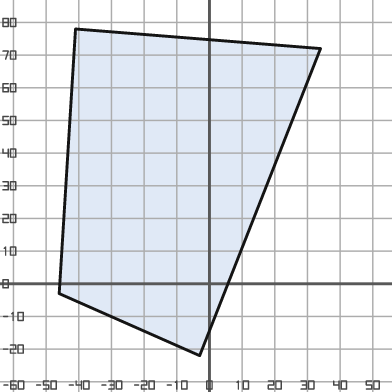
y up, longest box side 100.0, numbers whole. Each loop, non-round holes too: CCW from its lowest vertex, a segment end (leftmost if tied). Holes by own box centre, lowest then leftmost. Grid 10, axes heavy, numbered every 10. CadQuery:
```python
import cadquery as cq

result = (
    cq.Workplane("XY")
    .moveTo(-3.0, -22.0)
    .lineTo(34.0, 72.0)
    .lineTo(-41.0, 78.0)
    .lineTo(-46.0, -3.0)
    .close()
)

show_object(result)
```